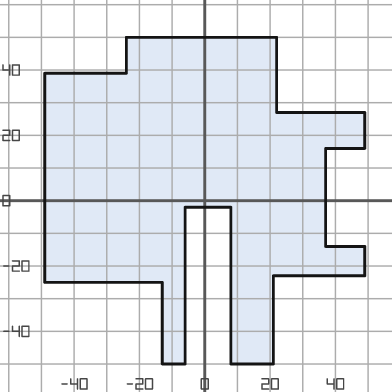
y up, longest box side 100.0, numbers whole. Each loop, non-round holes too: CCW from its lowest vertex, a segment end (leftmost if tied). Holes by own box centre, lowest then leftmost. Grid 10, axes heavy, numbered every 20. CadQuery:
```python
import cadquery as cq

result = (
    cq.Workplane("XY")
    .moveTo(-13.0, -50.0)
    .lineTo(-6.0, -50.0)
    .lineTo(-6.0, -2.0)
    .lineTo(8.0, -2.0)
    .lineTo(8.0, -50.0)
    .lineTo(21.0, -50.0)
    .lineTo(21.0, -23.0)
    .lineTo(49.0, -23.0)
    .lineTo(49.0, -14.0)
    .lineTo(37.0, -14.0)
    .lineTo(37.0, 16.0)
    .lineTo(49.0, 16.0)
    .lineTo(49.0, 27.0)
    .lineTo(22.0, 27.0)
    .lineTo(22.0, 50.0)
    .lineTo(-24.0, 50.0)
    .lineTo(-24.0, 39.0)
    .lineTo(-49.0, 39.0)
    .lineTo(-49.0, -25.0)
    .lineTo(-13.0, -25.0)
    .close()
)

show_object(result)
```